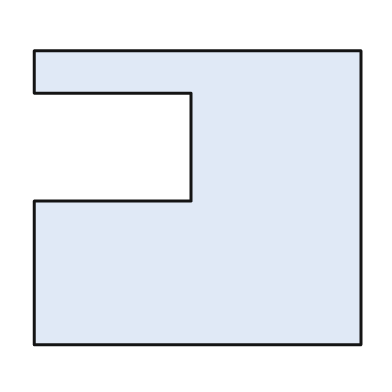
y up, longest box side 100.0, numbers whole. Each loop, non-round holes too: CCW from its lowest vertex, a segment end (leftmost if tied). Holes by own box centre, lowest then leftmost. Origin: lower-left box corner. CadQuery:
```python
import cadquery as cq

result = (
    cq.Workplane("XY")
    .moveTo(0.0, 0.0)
    .lineTo(100.0, 0.0)
    .lineTo(100.0, 90.0)
    .lineTo(0.0, 90.0)
    .lineTo(0.0, 77.0)
    .lineTo(48.0, 77.0)
    .lineTo(48.0, 44.0)
    .lineTo(0.0, 44.0)
    .close()
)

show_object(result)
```